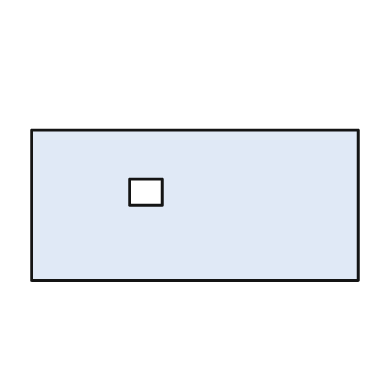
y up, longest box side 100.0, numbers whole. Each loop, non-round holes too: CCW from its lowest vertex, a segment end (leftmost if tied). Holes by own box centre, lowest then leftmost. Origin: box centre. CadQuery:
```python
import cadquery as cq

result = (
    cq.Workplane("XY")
    .moveTo(-50.0, -23.0)
    .lineTo(50.0, -23.0)
    .lineTo(50.0, 23.0)
    .lineTo(-50.0, 23.0)
    .close()
    .moveTo(-20.0, 0.0)
    .lineTo(-10.0, 0.0)
    .lineTo(-10.0, 8.0)
    .lineTo(-20.0, 8.0)
    .close()
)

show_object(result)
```